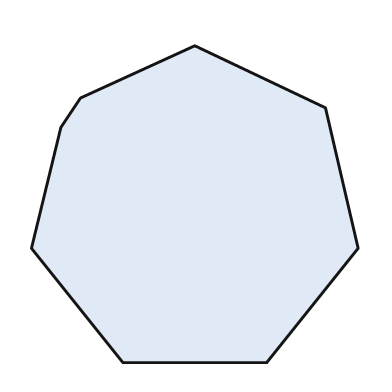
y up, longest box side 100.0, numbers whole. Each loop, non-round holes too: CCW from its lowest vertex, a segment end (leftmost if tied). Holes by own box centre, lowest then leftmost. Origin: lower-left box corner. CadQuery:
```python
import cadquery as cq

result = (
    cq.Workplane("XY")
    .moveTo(28.0, 0.0)
    .lineTo(72.0, 0.0)
    .lineTo(100.0, 35.0)
    .lineTo(90.0, 78.0)
    .lineTo(50.0, 97.0)
    .lineTo(15.0, 81.0)
    .lineTo(9.0, 72.0)
    .lineTo(0.0, 35.0)
    .close()
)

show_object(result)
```